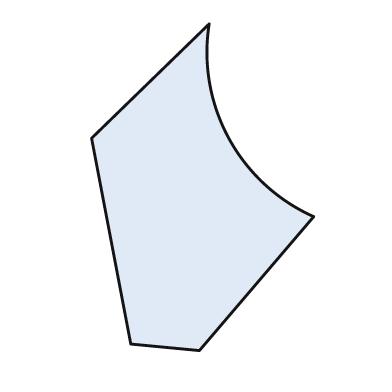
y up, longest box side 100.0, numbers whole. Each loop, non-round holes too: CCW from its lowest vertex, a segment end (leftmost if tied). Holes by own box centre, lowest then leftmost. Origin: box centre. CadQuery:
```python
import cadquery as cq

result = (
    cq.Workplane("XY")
    .moveTo(-1.0, -50.0)
    .lineTo(34.0, -9.0)
    .threePointArc((8.0, 15.0), (2.0, 50.0))
    .lineTo(-34.0, 15.0)
    .lineTo(-22.0, -48.0)
    .close()
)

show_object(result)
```